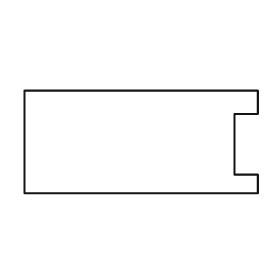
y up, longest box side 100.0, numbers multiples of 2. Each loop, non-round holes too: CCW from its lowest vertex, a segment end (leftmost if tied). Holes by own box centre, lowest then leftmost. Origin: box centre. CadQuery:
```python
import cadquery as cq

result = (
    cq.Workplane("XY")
    .moveTo(-50.0, -22.0)
    .lineTo(50.0, -22.0)
    .lineTo(50.0, -14.0)
    .lineTo(40.0, -14.0)
    .lineTo(40.0, 12.0)
    .lineTo(50.0, 12.0)
    .lineTo(50.0, 22.0)
    .lineTo(-50.0, 22.0)
    .close()
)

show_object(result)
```